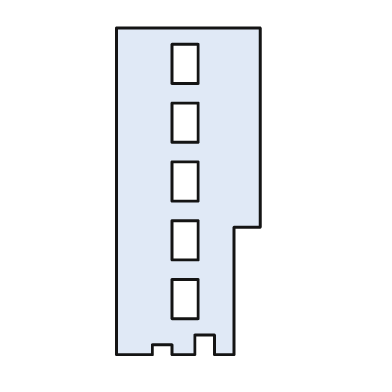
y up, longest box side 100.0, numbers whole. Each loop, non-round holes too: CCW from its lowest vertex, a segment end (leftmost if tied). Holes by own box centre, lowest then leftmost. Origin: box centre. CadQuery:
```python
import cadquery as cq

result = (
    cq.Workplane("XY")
    .moveTo(-22.0, -50.0)
    .lineTo(-11.0, -50.0)
    .lineTo(-11.0, -47.0)
    .lineTo(-5.0, -47.0)
    .lineTo(-5.0, -50.0)
    .lineTo(2.0, -50.0)
    .lineTo(2.0, -44.0)
    .lineTo(8.0, -44.0)
    .lineTo(8.0, -50.0)
    .lineTo(14.0, -50.0)
    .lineTo(14.0, -11.0)
    .lineTo(22.0, -11.0)
    .lineTo(22.0, 50.0)
    .lineTo(-22.0, 50.0)
    .close()
    .moveTo(-5.0, -39.0)
    .lineTo(3.0, -39.0)
    .lineTo(3.0, -27.0)
    .lineTo(-5.0, -27.0)
    .close()
    .moveTo(-5.0, -21.0)
    .lineTo(3.0, -21.0)
    .lineTo(3.0, -9.0)
    .lineTo(-5.0, -9.0)
    .close()
    .moveTo(-5.0, -3.0)
    .lineTo(3.0, -3.0)
    .lineTo(3.0, 9.0)
    .lineTo(-5.0, 9.0)
    .close()
    .moveTo(-5.0, 15.0)
    .lineTo(3.0, 15.0)
    .lineTo(3.0, 27.0)
    .lineTo(-5.0, 27.0)
    .close()
    .moveTo(-5.0, 33.0)
    .lineTo(3.0, 33.0)
    .lineTo(3.0, 45.0)
    .lineTo(-5.0, 45.0)
    .close()
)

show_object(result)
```